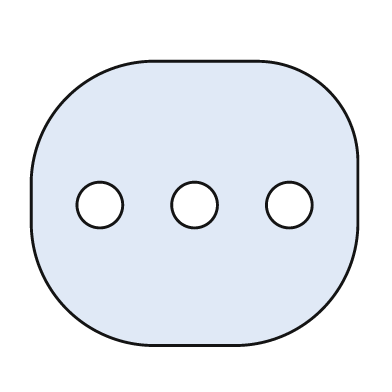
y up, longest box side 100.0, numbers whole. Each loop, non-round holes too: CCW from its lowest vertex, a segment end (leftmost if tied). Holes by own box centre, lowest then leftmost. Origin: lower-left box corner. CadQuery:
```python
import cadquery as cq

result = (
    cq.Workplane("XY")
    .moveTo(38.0, 0.0)
    .lineTo(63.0, 0.0)
    .threePointArc((89.0, 11.0), (100.0, 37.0))
    .lineTo(100.0, 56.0)
    .threePointArc((91.0, 78.0), (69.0, 87.0))
    .lineTo(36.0, 87.0)
    .threePointArc((11.0, 76.0), (0.0, 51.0))
    .lineTo(0.0, 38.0)
    .threePointArc((11.0, 11.0), (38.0, 0.0))
    .close()
    .moveTo(21.0, 43.0)
    .circle(7.0)
    .moveTo(50.0, 43.0)
    .circle(7.0)
    .moveTo(79.0, 43.0)
    .circle(7.0)
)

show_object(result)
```